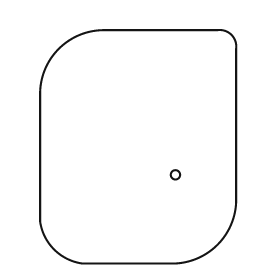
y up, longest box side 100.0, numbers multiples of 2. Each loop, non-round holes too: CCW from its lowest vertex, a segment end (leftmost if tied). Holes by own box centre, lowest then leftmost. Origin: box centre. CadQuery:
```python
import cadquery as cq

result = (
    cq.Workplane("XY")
    .moveTo(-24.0, -50.0)
    .lineTo(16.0, -50.0)
    .threePointArc((34.0, -42.0), (42.0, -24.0))
    .lineTo(42.0, 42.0)
    .threePointArc((40.0, 48.0), (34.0, 50.0))
    .lineTo(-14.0, 50.0)
    .threePointArc((-34.0, 42.0), (-42.0, 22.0))
    .lineTo(-42.0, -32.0)
    .threePointArc((-36.0, -44.0), (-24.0, -50.0))
    .close()
    .moveTo(16.0, -12.0)
    .circle(2.0)
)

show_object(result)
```